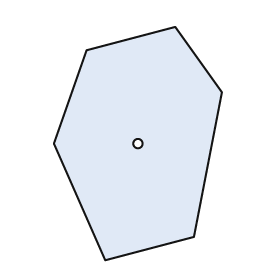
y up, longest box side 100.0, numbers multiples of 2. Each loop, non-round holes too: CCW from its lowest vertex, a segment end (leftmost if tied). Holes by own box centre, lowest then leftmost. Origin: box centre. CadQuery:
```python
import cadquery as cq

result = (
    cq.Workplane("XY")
    .moveTo(-14.0, -50.0)
    .lineTo(24.0, -40.0)
    .lineTo(36.0, 22.0)
    .lineTo(16.0, 50.0)
    .lineTo(-22.0, 40.0)
    .lineTo(-36.0, 0.0)
    .close()
    .moveTo(0.0, 0.0)
    .circle(2.0)
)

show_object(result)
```